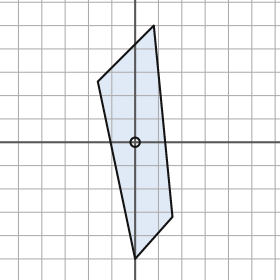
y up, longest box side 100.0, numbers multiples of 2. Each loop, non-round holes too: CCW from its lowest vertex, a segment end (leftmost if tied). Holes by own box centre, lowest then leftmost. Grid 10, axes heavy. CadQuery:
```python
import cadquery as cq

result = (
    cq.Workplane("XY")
    .moveTo(0.0, -50.0)
    .lineTo(16.0, -32.0)
    .lineTo(8.0, 50.0)
    .lineTo(-16.0, 26.0)
    .close()
    .moveTo(0.0, 0.0)
    .circle(2.0)
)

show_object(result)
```